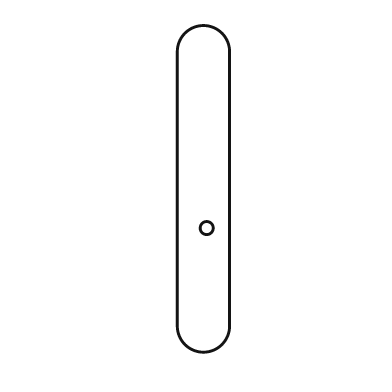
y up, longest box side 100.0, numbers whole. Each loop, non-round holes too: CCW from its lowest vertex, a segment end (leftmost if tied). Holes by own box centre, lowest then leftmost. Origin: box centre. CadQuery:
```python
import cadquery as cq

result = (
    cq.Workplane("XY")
    .moveTo(-8.0, -42.0)
    .threePointArc((0.0, -50.0), (8.0, -42.0))
    .lineTo(8.0, 42.0)
    .threePointArc((0.0, 50.0), (-8.0, 42.0))
    .close()
    .moveTo(1.0, -12.0)
    .circle(2.0)
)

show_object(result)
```